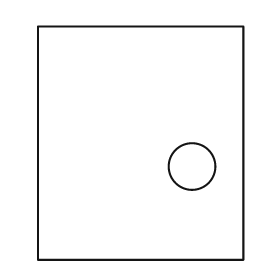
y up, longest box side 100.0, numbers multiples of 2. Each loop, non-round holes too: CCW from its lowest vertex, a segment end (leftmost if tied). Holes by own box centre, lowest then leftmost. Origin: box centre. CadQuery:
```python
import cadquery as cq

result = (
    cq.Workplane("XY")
    .moveTo(-44.0, -50.0)
    .lineTo(44.0, -50.0)
    .lineTo(44.0, 50.0)
    .lineTo(-44.0, 50.0)
    .close()
    .moveTo(22.0, -10.0)
    .circle(10.0)
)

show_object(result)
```